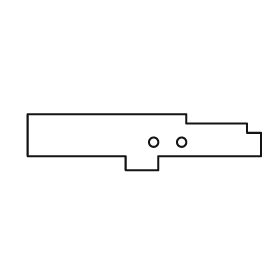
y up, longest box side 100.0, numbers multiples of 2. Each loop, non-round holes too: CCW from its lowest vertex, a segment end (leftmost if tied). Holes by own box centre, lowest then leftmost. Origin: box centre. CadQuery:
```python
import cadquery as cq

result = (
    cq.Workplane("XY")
    .moveTo(-8.0, -12.0)
    .lineTo(6.0, -12.0)
    .lineTo(6.0, -6.0)
    .lineTo(50.0, -6.0)
    .lineTo(50.0, 4.0)
    .lineTo(44.0, 4.0)
    .lineTo(44.0, 8.0)
    .lineTo(18.0, 8.0)
    .lineTo(18.0, 12.0)
    .lineTo(-50.0, 12.0)
    .lineTo(-50.0, -6.0)
    .lineTo(-8.0, -6.0)
    .close()
    .moveTo(4.0, 0.0)
    .circle(2.0)
    .moveTo(16.0, 0.0)
    .circle(2.0)
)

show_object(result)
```